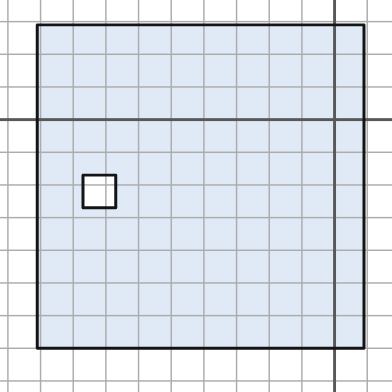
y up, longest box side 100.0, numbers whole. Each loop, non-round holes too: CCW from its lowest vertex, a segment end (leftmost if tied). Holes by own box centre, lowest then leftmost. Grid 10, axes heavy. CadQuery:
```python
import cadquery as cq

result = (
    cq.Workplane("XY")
    .moveTo(-91.0, -70.0)
    .lineTo(9.0, -70.0)
    .lineTo(9.0, 29.0)
    .lineTo(-91.0, 29.0)
    .close()
    .moveTo(-77.0, -27.0)
    .lineTo(-67.0, -27.0)
    .lineTo(-67.0, -17.0)
    .lineTo(-77.0, -17.0)
    .close()
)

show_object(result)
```